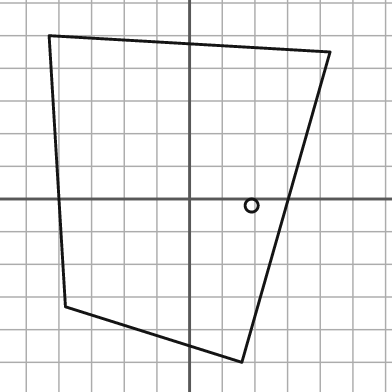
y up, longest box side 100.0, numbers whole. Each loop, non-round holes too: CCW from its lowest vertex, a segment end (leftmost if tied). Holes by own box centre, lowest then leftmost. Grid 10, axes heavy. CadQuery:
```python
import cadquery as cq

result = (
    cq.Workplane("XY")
    .moveTo(16.0, -50.0)
    .lineTo(43.0, 45.0)
    .lineTo(-43.0, 50.0)
    .lineTo(-38.0, -33.0)
    .close()
    .moveTo(19.0, -2.0)
    .circle(2.0)
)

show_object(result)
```